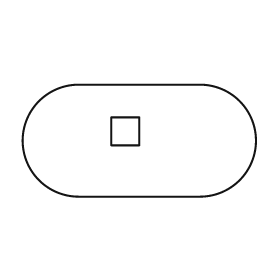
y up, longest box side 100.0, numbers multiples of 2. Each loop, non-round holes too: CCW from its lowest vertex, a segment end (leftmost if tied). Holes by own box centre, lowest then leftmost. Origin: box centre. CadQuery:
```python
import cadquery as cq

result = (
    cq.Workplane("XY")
    .moveTo(-26.0, -24.0)
    .lineTo(26.0, -24.0)
    .threePointArc((50.0, 0.0), (26.0, 24.0))
    .lineTo(-26.0, 24.0)
    .threePointArc((-50.0, 0.0), (-26.0, -24.0))
    .close()
    .moveTo(-12.0, -2.0)
    .lineTo(0.0, -2.0)
    .lineTo(0.0, 10.0)
    .lineTo(-12.0, 10.0)
    .close()
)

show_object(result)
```